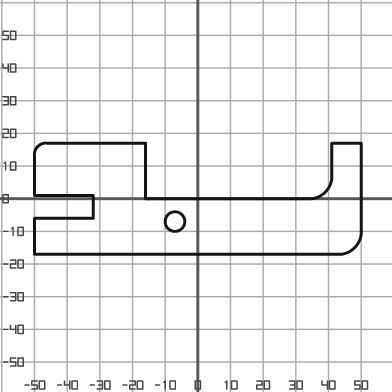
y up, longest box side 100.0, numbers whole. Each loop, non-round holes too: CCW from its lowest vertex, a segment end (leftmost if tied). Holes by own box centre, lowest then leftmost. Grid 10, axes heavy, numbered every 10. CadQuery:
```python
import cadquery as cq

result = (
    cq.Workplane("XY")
    .moveTo(-50.0, -17.0)
    .lineTo(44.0, -17.0)
    .threePointArc((48.0, -15.0), (50.0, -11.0))
    .lineTo(50.0, 17.0)
    .lineTo(41.0, 17.0)
    .lineTo(41.0, 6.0)
    .threePointArc((39.0, 2.0), (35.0, 0.0))
    .lineTo(-16.0, 0.0)
    .lineTo(-16.0, 17.0)
    .lineTo(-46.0, 17.0)
    .threePointArc((-49.0, 16.0), (-50.0, 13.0))
    .lineTo(-50.0, 1.0)
    .lineTo(-32.0, 1.0)
    .lineTo(-32.0, -6.0)
    .lineTo(-50.0, -6.0)
    .close()
    .moveTo(-7.0, -7.0)
    .circle(3.0)
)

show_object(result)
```